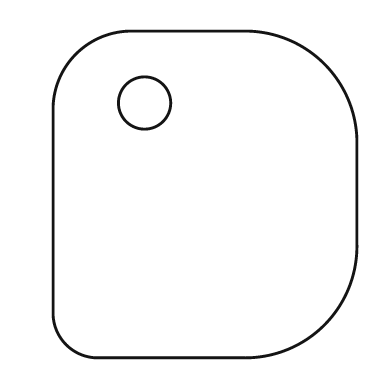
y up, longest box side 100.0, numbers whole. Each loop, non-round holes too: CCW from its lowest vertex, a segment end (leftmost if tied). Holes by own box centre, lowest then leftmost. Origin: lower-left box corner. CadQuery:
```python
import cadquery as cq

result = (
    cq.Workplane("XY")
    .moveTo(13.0, 0.0)
    .lineTo(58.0, 0.0)
    .threePointArc((83.0, 10.0), (93.0, 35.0))
    .lineTo(93.0, 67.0)
    .threePointArc((83.0, 90.0), (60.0, 100.0))
    .lineTo(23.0, 100.0)
    .threePointArc((7.0, 93.0), (0.0, 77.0))
    .lineTo(0.0, 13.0)
    .threePointArc((4.0, 4.0), (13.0, 0.0))
    .close()
    .moveTo(28.0, 78.0)
    .circle(8.0)
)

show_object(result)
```